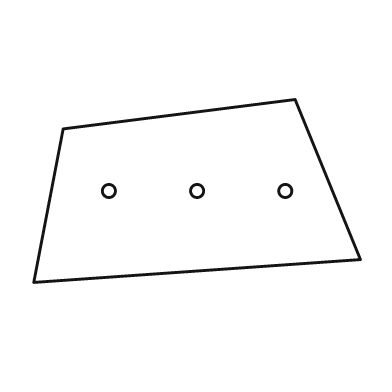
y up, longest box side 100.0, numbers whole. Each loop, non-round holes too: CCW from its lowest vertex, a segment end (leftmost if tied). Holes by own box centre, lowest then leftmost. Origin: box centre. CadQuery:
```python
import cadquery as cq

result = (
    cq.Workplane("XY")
    .moveTo(-50.0, -28.0)
    .lineTo(50.0, -21.0)
    .lineTo(30.0, 28.0)
    .lineTo(-41.0, 19.0)
    .close()
    .moveTo(-27.0, 0.0)
    .circle(2.0)
    .moveTo(0.0, 0.0)
    .circle(2.0)
    .moveTo(27.0, 0.0)
    .circle(2.0)
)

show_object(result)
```